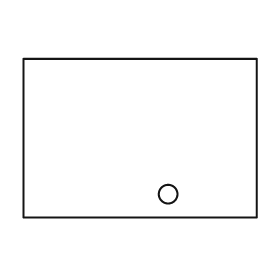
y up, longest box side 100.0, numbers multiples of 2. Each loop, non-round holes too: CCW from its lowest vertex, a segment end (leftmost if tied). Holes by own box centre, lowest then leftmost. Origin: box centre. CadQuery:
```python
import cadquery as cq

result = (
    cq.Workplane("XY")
    .moveTo(-50.0, -34.0)
    .lineTo(50.0, -34.0)
    .lineTo(50.0, 34.0)
    .lineTo(-50.0, 34.0)
    .close()
    .moveTo(12.0, -24.0)
    .circle(4.0)
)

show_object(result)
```